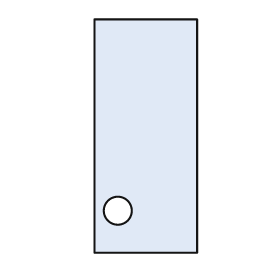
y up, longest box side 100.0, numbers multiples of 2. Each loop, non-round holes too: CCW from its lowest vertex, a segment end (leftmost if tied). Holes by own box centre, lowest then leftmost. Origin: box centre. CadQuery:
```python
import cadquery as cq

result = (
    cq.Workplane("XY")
    .moveTo(-22.0, -50.0)
    .lineTo(22.0, -50.0)
    .lineTo(22.0, 50.0)
    .lineTo(-22.0, 50.0)
    .close()
    .moveTo(-12.0, -32.0)
    .circle(6.0)
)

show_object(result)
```